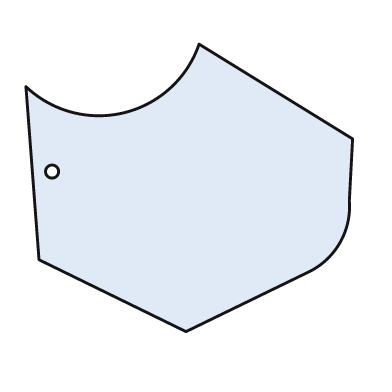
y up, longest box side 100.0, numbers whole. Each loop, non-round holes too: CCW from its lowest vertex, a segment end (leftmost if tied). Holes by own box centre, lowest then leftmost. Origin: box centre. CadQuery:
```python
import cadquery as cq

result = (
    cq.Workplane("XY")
    .moveTo(-1.0, -44.0)
    .lineTo(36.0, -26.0)
    .threePointArc((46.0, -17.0), (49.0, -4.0))
    .lineTo(50.0, 15.0)
    .lineTo(3.0, 44.0)
    .threePointArc((-20.0, 23.0), (-50.0, 31.0))
    .lineTo(-46.0, -22.0)
    .close()
    .moveTo(-42.0, 5.0)
    .circle(2.0)
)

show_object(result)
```